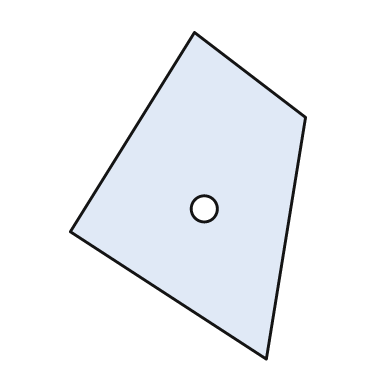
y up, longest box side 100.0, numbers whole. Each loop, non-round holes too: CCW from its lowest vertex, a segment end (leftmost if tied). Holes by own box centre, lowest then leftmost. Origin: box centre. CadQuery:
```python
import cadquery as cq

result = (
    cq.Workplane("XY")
    .moveTo(24.0, -50.0)
    .lineTo(36.0, 24.0)
    .lineTo(2.0, 50.0)
    .lineTo(-36.0, -11.0)
    .close()
    .moveTo(5.0, -4.0)
    .circle(4.0)
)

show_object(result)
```